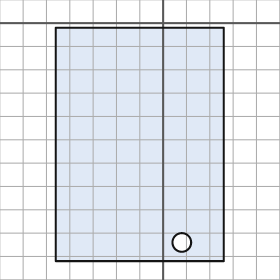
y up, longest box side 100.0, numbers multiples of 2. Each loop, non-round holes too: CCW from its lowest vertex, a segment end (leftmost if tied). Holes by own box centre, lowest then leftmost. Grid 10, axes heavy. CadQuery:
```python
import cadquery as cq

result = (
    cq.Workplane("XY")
    .moveTo(-46.0, -102.0)
    .lineTo(26.0, -102.0)
    .lineTo(26.0, -2.0)
    .lineTo(-46.0, -2.0)
    .close()
    .moveTo(8.0, -94.0)
    .circle(4.0)
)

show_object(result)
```